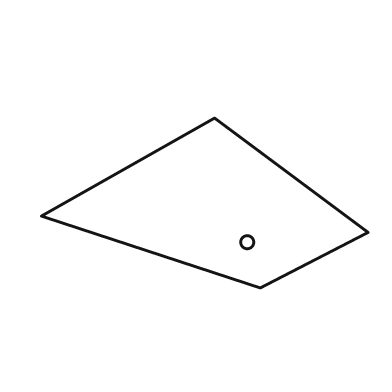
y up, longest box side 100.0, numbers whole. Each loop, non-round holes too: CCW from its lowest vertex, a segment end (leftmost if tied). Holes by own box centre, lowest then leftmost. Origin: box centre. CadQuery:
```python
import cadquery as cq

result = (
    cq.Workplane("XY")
    .moveTo(17.0, -26.0)
    .lineTo(50.0, -9.0)
    .lineTo(3.0, 26.0)
    .lineTo(-50.0, -4.0)
    .close()
    .moveTo(13.0, -12.0)
    .circle(2.0)
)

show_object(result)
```